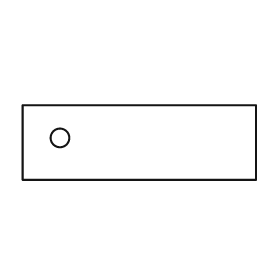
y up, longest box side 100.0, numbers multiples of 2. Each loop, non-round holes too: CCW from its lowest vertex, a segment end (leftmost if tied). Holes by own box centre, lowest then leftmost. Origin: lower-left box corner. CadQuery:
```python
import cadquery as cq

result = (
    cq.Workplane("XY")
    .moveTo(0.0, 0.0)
    .lineTo(100.0, 0.0)
    .lineTo(100.0, 32.0)
    .lineTo(0.0, 32.0)
    .close()
    .moveTo(16.0, 18.0)
    .circle(4.0)
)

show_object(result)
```